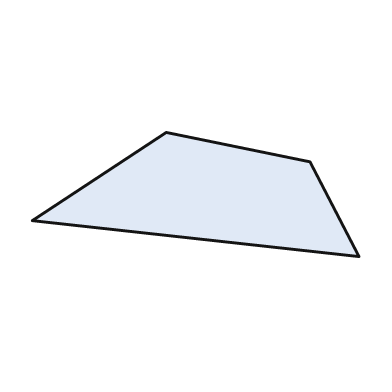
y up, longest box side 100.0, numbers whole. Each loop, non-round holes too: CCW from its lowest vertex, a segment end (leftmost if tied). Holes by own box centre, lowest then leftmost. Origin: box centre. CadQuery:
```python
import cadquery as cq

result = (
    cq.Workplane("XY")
    .moveTo(50.0, -19.0)
    .lineTo(35.0, 10.0)
    .lineTo(-9.0, 19.0)
    .lineTo(-50.0, -8.0)
    .close()
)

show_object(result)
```